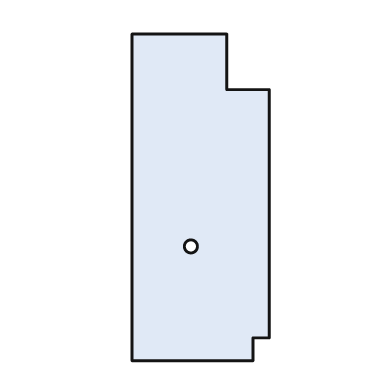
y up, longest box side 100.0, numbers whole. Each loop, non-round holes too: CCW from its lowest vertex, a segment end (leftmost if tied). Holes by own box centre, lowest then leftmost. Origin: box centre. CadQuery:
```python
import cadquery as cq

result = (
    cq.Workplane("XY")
    .moveTo(-21.0, -50.0)
    .lineTo(16.0, -50.0)
    .lineTo(16.0, -43.0)
    .lineTo(21.0, -43.0)
    .lineTo(21.0, 33.0)
    .lineTo(8.0, 33.0)
    .lineTo(8.0, 50.0)
    .lineTo(-21.0, 50.0)
    .close()
    .moveTo(-3.0, -15.0)
    .circle(2.0)
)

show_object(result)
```